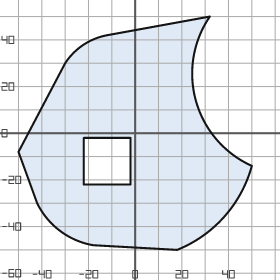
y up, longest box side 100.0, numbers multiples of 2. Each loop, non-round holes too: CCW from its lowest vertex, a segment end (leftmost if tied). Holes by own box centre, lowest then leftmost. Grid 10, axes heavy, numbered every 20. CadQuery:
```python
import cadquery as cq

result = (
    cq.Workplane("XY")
    .moveTo(18.0, -50.0)
    .threePointArc((38.0, -36.0), (50.0, -14.0))
    .threePointArc((26.0, 14.0), (32.0, 50.0))
    .lineTo(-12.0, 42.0)
    .threePointArc((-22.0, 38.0), (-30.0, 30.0))
    .lineTo(-50.0, -8.0)
    .lineTo(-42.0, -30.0)
    .threePointArc((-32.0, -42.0), (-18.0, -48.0))
    .close()
    .moveTo(-22.0, -22.0)
    .lineTo(-2.0, -22.0)
    .lineTo(-2.0, -2.0)
    .lineTo(-22.0, -2.0)
    .close()
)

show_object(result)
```